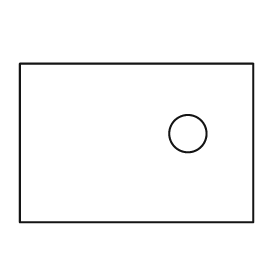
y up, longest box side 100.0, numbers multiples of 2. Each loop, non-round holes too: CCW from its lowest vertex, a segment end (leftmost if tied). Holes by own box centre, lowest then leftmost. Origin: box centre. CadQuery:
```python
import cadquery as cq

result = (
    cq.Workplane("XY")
    .moveTo(-50.0, -34.0)
    .lineTo(50.0, -34.0)
    .lineTo(50.0, 34.0)
    .lineTo(-50.0, 34.0)
    .close()
    .moveTo(22.0, 4.0)
    .circle(8.0)
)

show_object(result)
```